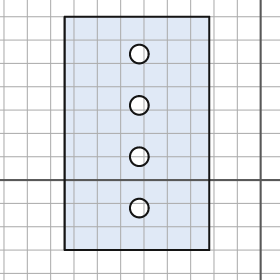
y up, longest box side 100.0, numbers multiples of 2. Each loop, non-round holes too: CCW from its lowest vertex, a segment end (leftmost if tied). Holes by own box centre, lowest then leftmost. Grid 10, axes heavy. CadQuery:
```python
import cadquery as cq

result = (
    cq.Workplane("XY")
    .moveTo(-84.0, -30.0)
    .lineTo(-22.0, -30.0)
    .lineTo(-22.0, 70.0)
    .lineTo(-84.0, 70.0)
    .close()
    .moveTo(-52.0, -12.0)
    .circle(4.0)
    .moveTo(-52.0, 10.0)
    .circle(4.0)
    .moveTo(-52.0, 32.0)
    .circle(4.0)
    .moveTo(-52.0, 54.0)
    .circle(4.0)
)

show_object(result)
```